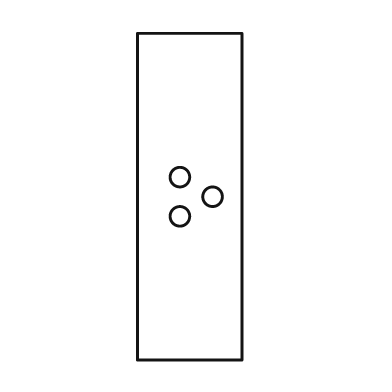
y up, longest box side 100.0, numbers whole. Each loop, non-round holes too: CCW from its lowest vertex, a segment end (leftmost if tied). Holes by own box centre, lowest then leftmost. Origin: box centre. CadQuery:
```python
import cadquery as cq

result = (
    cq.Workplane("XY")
    .moveTo(-16.0, -50.0)
    .lineTo(16.0, -50.0)
    .lineTo(16.0, 50.0)
    .lineTo(-16.0, 50.0)
    .close()
    .moveTo(-3.0, -6.0)
    .circle(3.0)
    .moveTo(7.0, 0.0)
    .circle(3.0)
    .moveTo(-3.0, 6.0)
    .circle(3.0)
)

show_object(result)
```